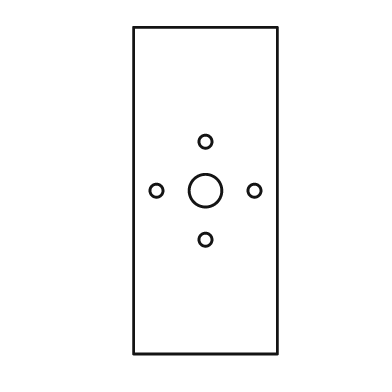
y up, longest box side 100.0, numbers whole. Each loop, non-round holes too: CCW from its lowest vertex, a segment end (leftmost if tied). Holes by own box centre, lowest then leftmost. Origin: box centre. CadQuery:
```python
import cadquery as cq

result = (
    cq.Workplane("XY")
    .moveTo(-22.0, -50.0)
    .lineTo(22.0, -50.0)
    .lineTo(22.0, 50.0)
    .lineTo(-22.0, 50.0)
    .close()
    .moveTo(0.0, -15.0)
    .circle(2.0)
    .moveTo(-15.0, 0.0)
    .circle(2.0)
    .moveTo(0.0, 0.0)
    .circle(5.0)
    .moveTo(15.0, 0.0)
    .circle(2.0)
    .moveTo(0.0, 15.0)
    .circle(2.0)
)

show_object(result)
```